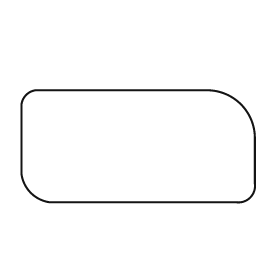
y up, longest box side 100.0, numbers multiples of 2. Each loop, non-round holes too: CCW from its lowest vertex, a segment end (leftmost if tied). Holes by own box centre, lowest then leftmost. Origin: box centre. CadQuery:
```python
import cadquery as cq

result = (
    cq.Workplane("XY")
    .moveTo(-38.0, -24.0)
    .lineTo(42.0, -24.0)
    .threePointArc((48.0, -22.0), (50.0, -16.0))
    .lineTo(50.0, 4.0)
    .threePointArc((44.0, 18.0), (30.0, 24.0))
    .lineTo(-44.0, 24.0)
    .threePointArc((-48.0, 22.0), (-50.0, 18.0))
    .lineTo(-50.0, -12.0)
    .threePointArc((-46.0, -20.0), (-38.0, -24.0))
    .close()
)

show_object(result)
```